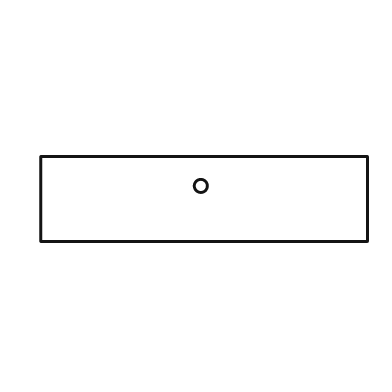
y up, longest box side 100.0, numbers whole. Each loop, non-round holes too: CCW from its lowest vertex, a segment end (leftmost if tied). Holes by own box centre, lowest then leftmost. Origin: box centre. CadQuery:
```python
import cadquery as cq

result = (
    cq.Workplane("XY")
    .moveTo(-50.0, -13.0)
    .lineTo(50.0, -13.0)
    .lineTo(50.0, 13.0)
    .lineTo(-50.0, 13.0)
    .close()
    .moveTo(-1.0, 4.0)
    .circle(2.0)
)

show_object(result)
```